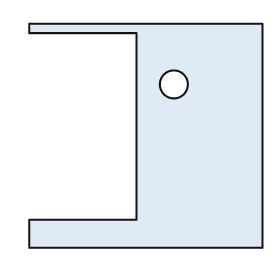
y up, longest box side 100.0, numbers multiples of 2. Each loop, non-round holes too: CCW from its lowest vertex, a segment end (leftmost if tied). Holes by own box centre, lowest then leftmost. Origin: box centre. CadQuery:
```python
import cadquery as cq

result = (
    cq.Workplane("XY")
    .moveTo(-50.0, -48.0)
    .lineTo(50.0, -48.0)
    .lineTo(50.0, 48.0)
    .lineTo(-50.0, 48.0)
    .lineTo(-50.0, 44.0)
    .lineTo(-4.0, 44.0)
    .lineTo(-4.0, -36.0)
    .lineTo(-50.0, -36.0)
    .close()
    .moveTo(12.0, 22.0)
    .circle(6.0)
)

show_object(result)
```